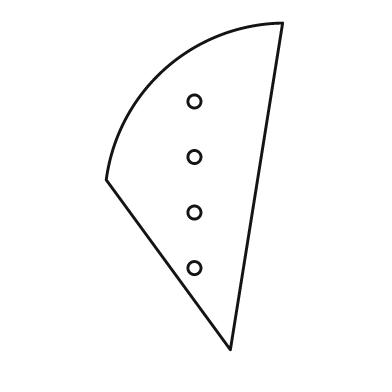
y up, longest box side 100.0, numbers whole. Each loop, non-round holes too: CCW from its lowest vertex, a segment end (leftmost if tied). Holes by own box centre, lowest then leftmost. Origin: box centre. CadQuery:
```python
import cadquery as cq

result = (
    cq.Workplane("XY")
    .moveTo(11.0, -50.0)
    .lineTo(27.0, 50.0)
    .threePointArc((-9.0, 36.0), (-27.0, 2.0))
    .close()
    .moveTo(0.0, -25.0)
    .circle(2.0)
    .moveTo(0.0, -8.0)
    .circle(2.0)
    .moveTo(0.0, 9.0)
    .circle(2.0)
    .moveTo(0.0, 26.0)
    .circle(2.0)
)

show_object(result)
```